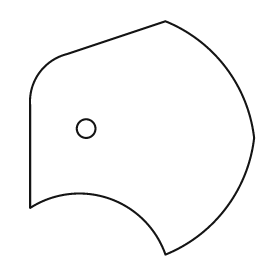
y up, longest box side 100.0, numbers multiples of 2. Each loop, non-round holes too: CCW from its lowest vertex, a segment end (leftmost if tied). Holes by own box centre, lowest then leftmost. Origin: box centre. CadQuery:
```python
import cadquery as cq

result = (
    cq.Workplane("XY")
    .moveTo(10.0, -50.0)
    .threePointArc((36.0, -30.0), (48.0, 0.0))
    .threePointArc((36.0, 30.0), (10.0, 50.0))
    .lineTo(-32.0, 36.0)
    .threePointArc((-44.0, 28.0), (-48.0, 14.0))
    .lineTo(-48.0, -30.0)
    .threePointArc((-14.0, -26.0), (10.0, -50.0))
    .close()
    .moveTo(-24.0, 4.0)
    .circle(4.0)
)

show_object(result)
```